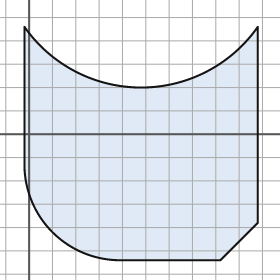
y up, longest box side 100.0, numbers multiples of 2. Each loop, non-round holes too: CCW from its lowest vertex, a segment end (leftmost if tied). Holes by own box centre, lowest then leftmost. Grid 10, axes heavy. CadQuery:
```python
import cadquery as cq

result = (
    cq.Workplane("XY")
    .moveTo(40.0, -54.0)
    .lineTo(82.0, -54.0)
    .lineTo(98.0, -38.0)
    .lineTo(98.0, 46.0)
    .threePointArc((48.0, 20.0), (-2.0, 46.0))
    .lineTo(-2.0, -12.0)
    .threePointArc((10.0, -42.0), (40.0, -54.0))
    .close()
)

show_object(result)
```